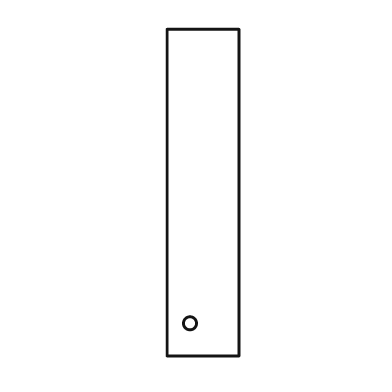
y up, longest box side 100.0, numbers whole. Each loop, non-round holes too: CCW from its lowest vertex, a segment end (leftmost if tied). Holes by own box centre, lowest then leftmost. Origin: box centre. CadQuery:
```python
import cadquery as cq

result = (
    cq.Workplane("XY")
    .moveTo(-11.0, -50.0)
    .lineTo(11.0, -50.0)
    .lineTo(11.0, 50.0)
    .lineTo(-11.0, 50.0)
    .close()
    .moveTo(-4.0, -40.0)
    .circle(2.0)
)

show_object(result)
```